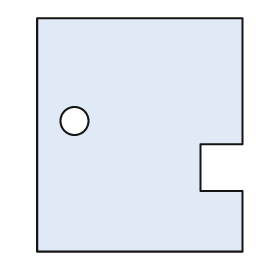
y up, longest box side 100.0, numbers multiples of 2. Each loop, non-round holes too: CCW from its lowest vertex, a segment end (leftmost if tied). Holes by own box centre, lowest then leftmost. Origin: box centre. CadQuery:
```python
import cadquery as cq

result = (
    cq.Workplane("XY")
    .moveTo(-44.0, -50.0)
    .lineTo(44.0, -50.0)
    .lineTo(44.0, -24.0)
    .lineTo(26.0, -24.0)
    .lineTo(26.0, -4.0)
    .lineTo(44.0, -4.0)
    .lineTo(44.0, 50.0)
    .lineTo(-44.0, 50.0)
    .close()
    .moveTo(-28.0, 6.0)
    .circle(6.0)
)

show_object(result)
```